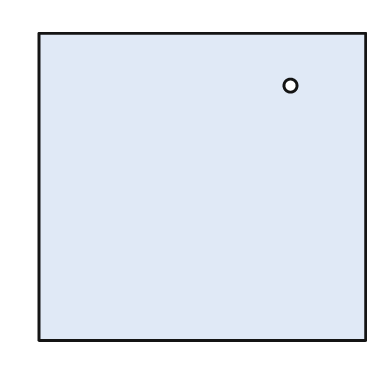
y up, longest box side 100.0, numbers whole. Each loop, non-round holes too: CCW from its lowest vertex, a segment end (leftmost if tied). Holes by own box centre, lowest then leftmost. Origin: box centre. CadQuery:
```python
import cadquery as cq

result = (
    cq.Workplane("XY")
    .moveTo(-50.0, -47.0)
    .lineTo(50.0, -47.0)
    .lineTo(50.0, 47.0)
    .lineTo(-50.0, 47.0)
    .close()
    .moveTo(27.0, 31.0)
    .circle(2.0)
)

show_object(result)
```